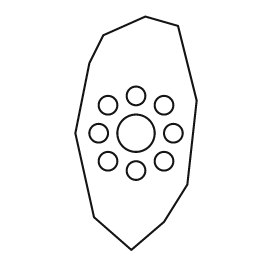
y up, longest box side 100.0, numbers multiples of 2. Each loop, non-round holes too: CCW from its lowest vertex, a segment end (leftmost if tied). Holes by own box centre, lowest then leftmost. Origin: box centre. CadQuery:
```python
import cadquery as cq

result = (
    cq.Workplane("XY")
    .moveTo(-2.0, -50.0)
    .lineTo(12.0, -38.0)
    .lineTo(22.0, -22.0)
    .lineTo(26.0, 14.0)
    .lineTo(18.0, 46.0)
    .lineTo(4.0, 50.0)
    .lineTo(-14.0, 42.0)
    .lineTo(-20.0, 30.0)
    .lineTo(-26.0, 0.0)
    .lineTo(-18.0, -36.0)
    .close()
    .moveTo(0.0, -16.0)
    .circle(4.0)
    .moveTo(-12.0, -12.0)
    .circle(4.0)
    .moveTo(12.0, -12.0)
    .circle(4.0)
    .moveTo(-16.0, 0.0)
    .circle(4.0)
    .moveTo(0.0, 0.0)
    .circle(8.0)
    .moveTo(16.0, 0.0)
    .circle(4.0)
    .moveTo(-12.0, 12.0)
    .circle(4.0)
    .moveTo(12.0, 12.0)
    .circle(4.0)
    .moveTo(0.0, 16.0)
    .circle(4.0)
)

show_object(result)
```